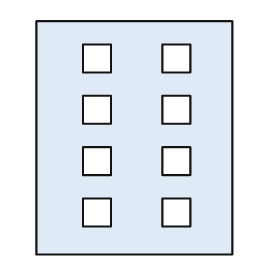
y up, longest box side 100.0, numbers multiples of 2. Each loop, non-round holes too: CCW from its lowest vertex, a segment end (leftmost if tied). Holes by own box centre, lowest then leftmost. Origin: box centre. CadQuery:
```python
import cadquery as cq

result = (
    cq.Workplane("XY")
    .moveTo(-42.0, -50.0)
    .lineTo(42.0, -50.0)
    .lineTo(42.0, 50.0)
    .lineTo(-42.0, 50.0)
    .close()
    .moveTo(-22.0, -38.0)
    .lineTo(-10.0, -38.0)
    .lineTo(-10.0, -26.0)
    .lineTo(-22.0, -26.0)
    .close()
    .moveTo(12.0, -38.0)
    .lineTo(24.0, -38.0)
    .lineTo(24.0, -26.0)
    .lineTo(12.0, -26.0)
    .close()
    .moveTo(-22.0, -16.0)
    .lineTo(-10.0, -16.0)
    .lineTo(-10.0, -4.0)
    .lineTo(-22.0, -4.0)
    .close()
    .moveTo(12.0, -16.0)
    .lineTo(24.0, -16.0)
    .lineTo(24.0, -4.0)
    .lineTo(12.0, -4.0)
    .close()
    .moveTo(-22.0, 6.0)
    .lineTo(-10.0, 6.0)
    .lineTo(-10.0, 18.0)
    .lineTo(-22.0, 18.0)
    .close()
    .moveTo(12.0, 6.0)
    .lineTo(24.0, 6.0)
    .lineTo(24.0, 18.0)
    .lineTo(12.0, 18.0)
    .close()
    .moveTo(-22.0, 28.0)
    .lineTo(-10.0, 28.0)
    .lineTo(-10.0, 40.0)
    .lineTo(-22.0, 40.0)
    .close()
    .moveTo(12.0, 28.0)
    .lineTo(24.0, 28.0)
    .lineTo(24.0, 40.0)
    .lineTo(12.0, 40.0)
    .close()
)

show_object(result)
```